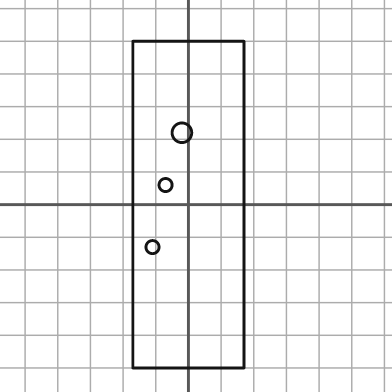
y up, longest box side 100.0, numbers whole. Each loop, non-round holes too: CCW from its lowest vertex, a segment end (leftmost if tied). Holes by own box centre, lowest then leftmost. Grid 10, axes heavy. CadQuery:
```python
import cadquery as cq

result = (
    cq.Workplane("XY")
    .moveTo(-17.0, -50.0)
    .lineTo(17.0, -50.0)
    .lineTo(17.0, 50.0)
    .lineTo(-17.0, 50.0)
    .close()
    .moveTo(-11.0, -13.0)
    .circle(2.0)
    .moveTo(-7.0, 6.0)
    .circle(2.0)
    .moveTo(-2.0, 22.0)
    .circle(3.0)
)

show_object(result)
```